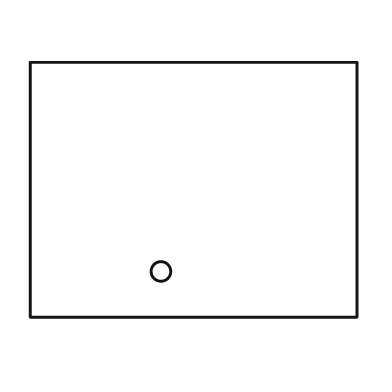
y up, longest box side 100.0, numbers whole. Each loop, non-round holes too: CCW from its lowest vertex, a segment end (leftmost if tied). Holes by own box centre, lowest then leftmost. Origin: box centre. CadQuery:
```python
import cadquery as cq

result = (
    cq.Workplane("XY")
    .moveTo(-50.0, -39.0)
    .lineTo(50.0, -39.0)
    .lineTo(50.0, 39.0)
    .lineTo(-50.0, 39.0)
    .close()
    .moveTo(-10.0, -25.0)
    .circle(3.0)
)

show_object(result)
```